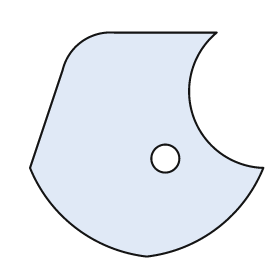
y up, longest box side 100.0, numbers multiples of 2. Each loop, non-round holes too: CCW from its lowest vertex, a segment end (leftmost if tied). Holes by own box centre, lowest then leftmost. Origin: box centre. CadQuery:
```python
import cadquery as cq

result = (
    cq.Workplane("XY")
    .moveTo(0.0, -48.0)
    .threePointArc((30.0, -36.0), (50.0, -10.0))
    .threePointArc((20.0, 12.0), (30.0, 48.0))
    .lineTo(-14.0, 48.0)
    .threePointArc((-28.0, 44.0), (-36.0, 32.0))
    .lineTo(-50.0, -10.0)
    .threePointArc((-30.0, -36.0), (0.0, -48.0))
    .close()
    .moveTo(8.0, -6.0)
    .circle(6.0)
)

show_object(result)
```